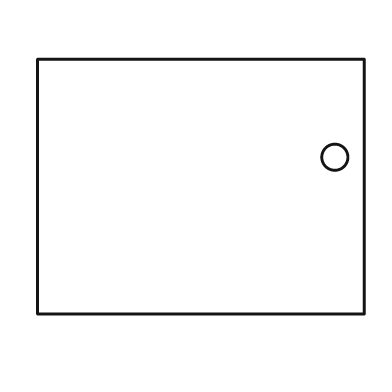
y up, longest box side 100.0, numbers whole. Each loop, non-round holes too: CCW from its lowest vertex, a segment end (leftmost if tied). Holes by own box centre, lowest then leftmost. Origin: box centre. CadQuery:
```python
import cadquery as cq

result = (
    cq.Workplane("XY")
    .moveTo(-50.0, -39.0)
    .lineTo(50.0, -39.0)
    .lineTo(50.0, 39.0)
    .lineTo(-50.0, 39.0)
    .close()
    .moveTo(41.0, 9.0)
    .circle(4.0)
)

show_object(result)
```